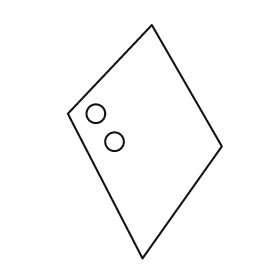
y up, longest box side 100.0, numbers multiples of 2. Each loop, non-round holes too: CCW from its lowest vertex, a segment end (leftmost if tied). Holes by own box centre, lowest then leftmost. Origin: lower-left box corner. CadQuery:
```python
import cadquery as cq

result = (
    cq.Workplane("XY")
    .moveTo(32.0, 0.0)
    .lineTo(66.0, 48.0)
    .lineTo(36.0, 100.0)
    .lineTo(0.0, 62.0)
    .close()
    .moveTo(20.0, 50.0)
    .circle(4.0)
    .moveTo(12.0, 62.0)
    .circle(4.0)
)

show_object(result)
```